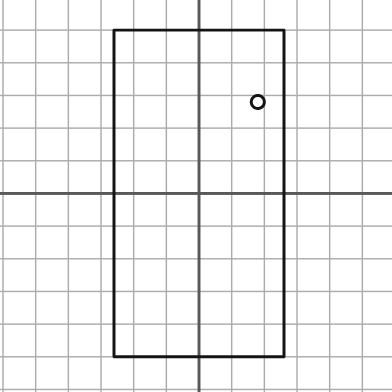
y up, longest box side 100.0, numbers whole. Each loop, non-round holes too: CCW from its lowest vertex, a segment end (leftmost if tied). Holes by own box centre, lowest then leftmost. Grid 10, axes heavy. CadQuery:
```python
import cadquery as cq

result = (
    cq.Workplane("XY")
    .moveTo(-26.0, -50.0)
    .lineTo(26.0, -50.0)
    .lineTo(26.0, 50.0)
    .lineTo(-26.0, 50.0)
    .close()
    .moveTo(18.0, 28.0)
    .circle(2.0)
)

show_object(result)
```